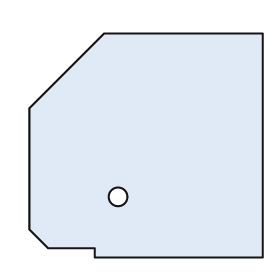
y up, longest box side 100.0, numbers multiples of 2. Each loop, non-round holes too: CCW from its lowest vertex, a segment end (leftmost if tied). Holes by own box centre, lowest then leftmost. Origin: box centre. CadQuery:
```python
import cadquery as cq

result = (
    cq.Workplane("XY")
    .moveTo(-22.0, -48.0)
    .lineTo(50.0, -48.0)
    .lineTo(50.0, 48.0)
    .lineTo(-18.0, 48.0)
    .lineTo(-50.0, 16.0)
    .lineTo(-50.0, -36.0)
    .lineTo(-42.0, -44.0)
    .lineTo(-22.0, -44.0)
    .close()
    .moveTo(-12.0, -22.0)
    .circle(4.0)
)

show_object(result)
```